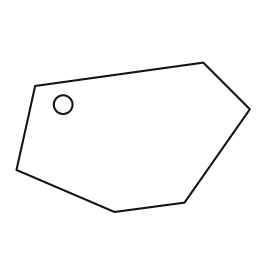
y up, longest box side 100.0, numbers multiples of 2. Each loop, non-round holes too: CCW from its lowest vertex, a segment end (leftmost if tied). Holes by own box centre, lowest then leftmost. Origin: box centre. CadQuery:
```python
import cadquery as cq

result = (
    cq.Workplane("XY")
    .moveTo(-8.0, -32.0)
    .lineTo(22.0, -28.0)
    .lineTo(50.0, 12.0)
    .lineTo(30.0, 32.0)
    .lineTo(-42.0, 22.0)
    .lineTo(-50.0, -14.0)
    .close()
    .moveTo(-30.0, 14.0)
    .circle(4.0)
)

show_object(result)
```